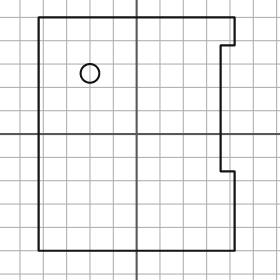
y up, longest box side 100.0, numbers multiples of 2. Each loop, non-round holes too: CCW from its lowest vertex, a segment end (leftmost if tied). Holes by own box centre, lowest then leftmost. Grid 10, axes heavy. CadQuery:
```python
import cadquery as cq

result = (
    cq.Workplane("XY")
    .moveTo(-42.0, -50.0)
    .lineTo(42.0, -50.0)
    .lineTo(42.0, -16.0)
    .lineTo(36.0, -16.0)
    .lineTo(36.0, 38.0)
    .lineTo(42.0, 38.0)
    .lineTo(42.0, 50.0)
    .lineTo(-42.0, 50.0)
    .close()
    .moveTo(-20.0, 26.0)
    .circle(4.0)
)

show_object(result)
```